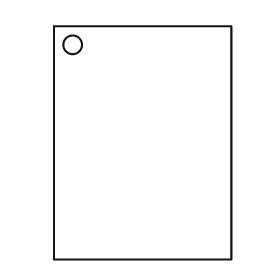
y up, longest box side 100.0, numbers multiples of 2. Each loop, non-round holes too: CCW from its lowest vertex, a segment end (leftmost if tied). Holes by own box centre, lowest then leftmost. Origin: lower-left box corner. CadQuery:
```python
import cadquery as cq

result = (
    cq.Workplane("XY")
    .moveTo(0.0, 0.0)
    .lineTo(76.0, 0.0)
    .lineTo(76.0, 100.0)
    .lineTo(0.0, 100.0)
    .close()
    .moveTo(8.0, 92.0)
    .circle(4.0)
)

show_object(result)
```